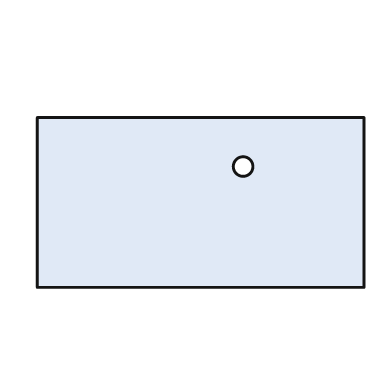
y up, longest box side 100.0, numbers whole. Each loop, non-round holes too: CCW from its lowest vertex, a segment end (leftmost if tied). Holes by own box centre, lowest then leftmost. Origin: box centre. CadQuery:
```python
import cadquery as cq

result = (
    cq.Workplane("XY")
    .moveTo(-50.0, -26.0)
    .lineTo(50.0, -26.0)
    .lineTo(50.0, 26.0)
    .lineTo(-50.0, 26.0)
    .close()
    .moveTo(13.0, 11.0)
    .circle(3.0)
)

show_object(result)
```